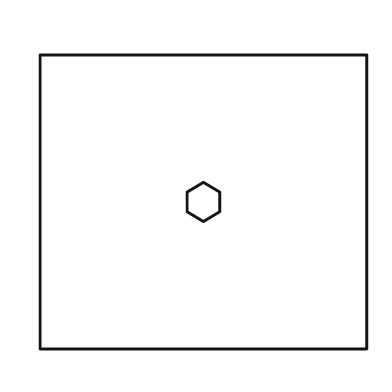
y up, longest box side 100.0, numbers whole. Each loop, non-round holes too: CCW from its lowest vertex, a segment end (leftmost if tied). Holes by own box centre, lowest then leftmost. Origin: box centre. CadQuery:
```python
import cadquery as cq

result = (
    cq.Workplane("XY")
    .moveTo(-50.0, -45.0)
    .lineTo(50.0, -45.0)
    .lineTo(50.0, 45.0)
    .lineTo(-50.0, 45.0)
    .close()
    .moveTo(0.0, -6.0)
    .lineTo(5.0, -3.0)
    .lineTo(5.0, 3.0)
    .lineTo(0.0, 6.0)
    .lineTo(-5.0, 3.0)
    .lineTo(-5.0, -3.0)
    .close()
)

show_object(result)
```